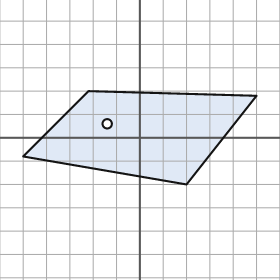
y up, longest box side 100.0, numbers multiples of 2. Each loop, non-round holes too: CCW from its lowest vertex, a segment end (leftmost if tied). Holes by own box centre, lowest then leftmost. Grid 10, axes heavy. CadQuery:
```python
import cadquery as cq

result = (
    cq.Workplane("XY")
    .moveTo(20.0, -20.0)
    .lineTo(50.0, 18.0)
    .lineTo(-22.0, 20.0)
    .lineTo(-50.0, -8.0)
    .close()
    .moveTo(-14.0, 6.0)
    .circle(2.0)
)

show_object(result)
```